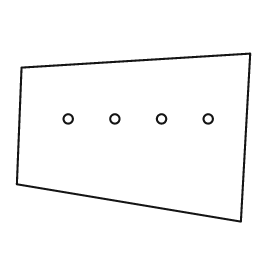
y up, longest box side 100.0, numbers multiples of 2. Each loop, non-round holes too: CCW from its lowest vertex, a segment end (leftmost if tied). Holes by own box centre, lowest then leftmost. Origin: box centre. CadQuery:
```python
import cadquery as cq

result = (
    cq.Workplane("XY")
    .moveTo(46.0, -36.0)
    .lineTo(50.0, 36.0)
    .lineTo(-48.0, 30.0)
    .lineTo(-50.0, -20.0)
    .close()
    .moveTo(-28.0, 8.0)
    .circle(2.0)
    .moveTo(-8.0, 8.0)
    .circle(2.0)
    .moveTo(12.0, 8.0)
    .circle(2.0)
    .moveTo(32.0, 8.0)
    .circle(2.0)
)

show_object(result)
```